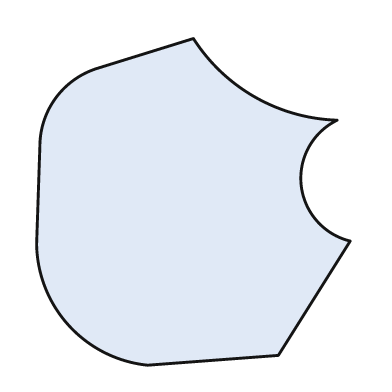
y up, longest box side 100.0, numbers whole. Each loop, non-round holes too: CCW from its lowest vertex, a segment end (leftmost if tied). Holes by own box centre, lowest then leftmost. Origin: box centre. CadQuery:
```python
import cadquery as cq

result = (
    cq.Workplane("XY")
    .moveTo(-14.0, -50.0)
    .lineTo(26.0, -47.0)
    .lineTo(48.0, -12.0)
    .threePointArc((33.0, 5.0), (44.0, 25.0))
    .threePointArc((19.0, 32.0), (0.0, 50.0))
    .lineTo(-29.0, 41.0)
    .threePointArc((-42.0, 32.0), (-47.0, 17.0))
    .lineTo(-48.0, -13.0)
    .threePointArc((-38.0, -38.0), (-14.0, -50.0))
    .close()
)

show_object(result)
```